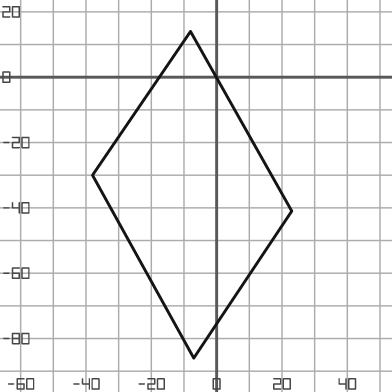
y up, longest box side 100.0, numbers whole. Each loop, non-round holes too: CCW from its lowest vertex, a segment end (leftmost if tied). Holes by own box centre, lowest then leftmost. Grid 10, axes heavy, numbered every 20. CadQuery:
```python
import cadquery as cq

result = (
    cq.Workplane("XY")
    .moveTo(-7.0, -86.0)
    .lineTo(23.0, -41.0)
    .lineTo(-8.0, 14.0)
    .lineTo(-38.0, -30.0)
    .close()
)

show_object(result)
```